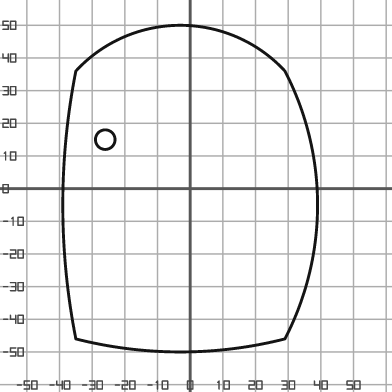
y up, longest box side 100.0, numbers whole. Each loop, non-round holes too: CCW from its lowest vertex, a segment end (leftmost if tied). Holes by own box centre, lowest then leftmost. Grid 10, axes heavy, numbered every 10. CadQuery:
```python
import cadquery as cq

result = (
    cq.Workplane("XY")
    .moveTo(-35.0, -46.0)
    .threePointArc((-3.0, -50.0), (29.0, -46.0))
    .threePointArc((39.0, -5.0), (29.0, 36.0))
    .threePointArc((-3.0, 50.0), (-35.0, 36.0))
    .threePointArc((-39.0, -5.0), (-35.0, -46.0))
    .close()
    .moveTo(-26.0, 15.0)
    .circle(3.0)
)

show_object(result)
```